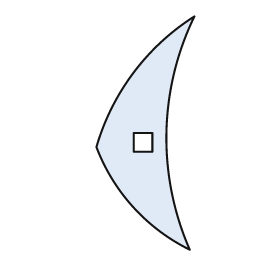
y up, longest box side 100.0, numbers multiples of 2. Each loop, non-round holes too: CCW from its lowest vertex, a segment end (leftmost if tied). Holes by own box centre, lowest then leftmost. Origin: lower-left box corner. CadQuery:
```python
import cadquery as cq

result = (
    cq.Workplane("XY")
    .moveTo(40.0, 0.0)
    .threePointArc((30.0, 50.0), (42.0, 100.0))
    .threePointArc((16.0, 76.0), (0.0, 44.0))
    .threePointArc((16.0, 18.0), (40.0, 0.0))
    .close()
    .moveTo(16.0, 42.0)
    .lineTo(24.0, 42.0)
    .lineTo(24.0, 50.0)
    .lineTo(16.0, 50.0)
    .close()
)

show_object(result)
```